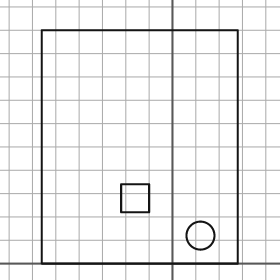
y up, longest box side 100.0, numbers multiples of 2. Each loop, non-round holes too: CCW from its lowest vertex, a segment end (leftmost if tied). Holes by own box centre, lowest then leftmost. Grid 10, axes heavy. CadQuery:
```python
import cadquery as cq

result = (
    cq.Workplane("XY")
    .moveTo(-56.0, 0.0)
    .lineTo(28.0, 0.0)
    .lineTo(28.0, 100.0)
    .lineTo(-56.0, 100.0)
    .close()
    .moveTo(12.0, 12.0)
    .circle(6.0)
    .moveTo(-22.0, 22.0)
    .lineTo(-10.0, 22.0)
    .lineTo(-10.0, 34.0)
    .lineTo(-22.0, 34.0)
    .close()
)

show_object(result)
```